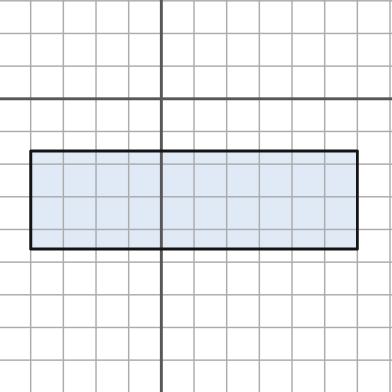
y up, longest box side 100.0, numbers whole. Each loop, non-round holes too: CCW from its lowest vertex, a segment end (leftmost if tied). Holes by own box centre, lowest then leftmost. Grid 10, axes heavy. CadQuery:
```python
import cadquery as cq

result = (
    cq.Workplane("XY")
    .moveTo(-40.0, -46.0)
    .lineTo(60.0, -46.0)
    .lineTo(60.0, -16.0)
    .lineTo(-40.0, -16.0)
    .close()
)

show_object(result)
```